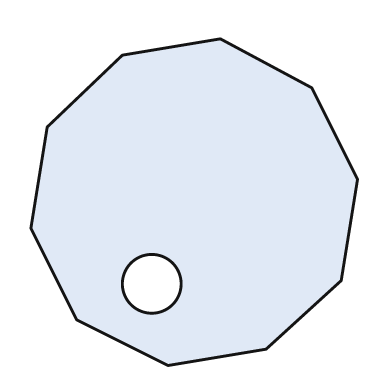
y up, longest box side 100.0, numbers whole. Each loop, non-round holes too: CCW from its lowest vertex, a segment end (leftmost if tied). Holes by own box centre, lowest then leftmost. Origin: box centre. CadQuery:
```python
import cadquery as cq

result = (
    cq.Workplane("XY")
    .moveTo(-8.0, -50.0)
    .lineTo(22.0, -45.0)
    .lineTo(45.0, -24.0)
    .lineTo(50.0, 7.0)
    .lineTo(36.0, 35.0)
    .lineTo(8.0, 50.0)
    .lineTo(-22.0, 45.0)
    .lineTo(-45.0, 23.0)
    .lineTo(-50.0, -8.0)
    .lineTo(-36.0, -36.0)
    .close()
    .moveTo(-13.0, -25.0)
    .circle(9.0)
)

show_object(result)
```